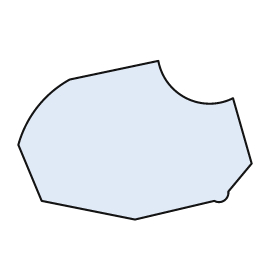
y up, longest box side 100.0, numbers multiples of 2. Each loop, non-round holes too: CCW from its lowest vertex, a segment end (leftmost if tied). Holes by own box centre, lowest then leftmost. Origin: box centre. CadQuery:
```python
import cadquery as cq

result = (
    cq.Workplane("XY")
    .moveTo(0.0, -34.0)
    .lineTo(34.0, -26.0)
    .threePointArc((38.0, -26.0), (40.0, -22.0))
    .lineTo(50.0, -10.0)
    .lineTo(42.0, 18.0)
    .threePointArc((22.0, 18.0), (10.0, 34.0))
    .lineTo(-28.0, 26.0)
    .threePointArc((-42.0, 14.0), (-50.0, -2.0))
    .lineTo(-40.0, -26.0)
    .close()
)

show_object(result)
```